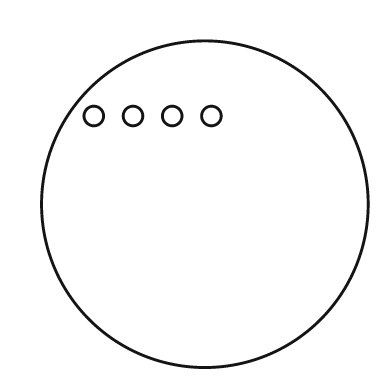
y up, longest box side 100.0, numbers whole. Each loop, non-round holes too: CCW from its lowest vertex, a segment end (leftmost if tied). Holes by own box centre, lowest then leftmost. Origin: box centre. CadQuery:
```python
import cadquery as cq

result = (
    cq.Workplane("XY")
    .moveTo(0.0, 0.0)
    .circle(50.0)
    .moveTo(-34.0, 27.0)
    .circle(3.0)
    .moveTo(-22.0, 27.0)
    .circle(3.0)
    .moveTo(-10.0, 27.0)
    .circle(3.0)
    .moveTo(2.0, 27.0)
    .circle(3.0)
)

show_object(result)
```